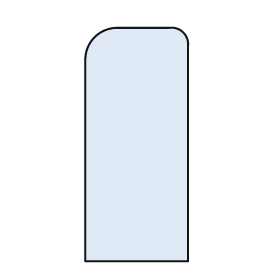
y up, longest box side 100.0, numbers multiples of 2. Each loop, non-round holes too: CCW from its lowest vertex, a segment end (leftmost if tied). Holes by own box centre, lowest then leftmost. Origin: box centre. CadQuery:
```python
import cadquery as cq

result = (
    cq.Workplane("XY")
    .moveTo(-22.0, -50.0)
    .lineTo(22.0, -50.0)
    .lineTo(22.0, 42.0)
    .threePointArc((20.0, 48.0), (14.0, 50.0))
    .lineTo(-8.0, 50.0)
    .threePointArc((-18.0, 46.0), (-22.0, 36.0))
    .close()
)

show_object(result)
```